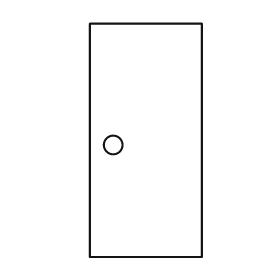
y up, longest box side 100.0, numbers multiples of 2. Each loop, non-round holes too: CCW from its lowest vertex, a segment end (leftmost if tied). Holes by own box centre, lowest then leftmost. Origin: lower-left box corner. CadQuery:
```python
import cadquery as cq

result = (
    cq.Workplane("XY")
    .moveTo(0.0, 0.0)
    .lineTo(48.0, 0.0)
    .lineTo(48.0, 100.0)
    .lineTo(0.0, 100.0)
    .close()
    .moveTo(10.0, 48.0)
    .circle(4.0)
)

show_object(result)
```